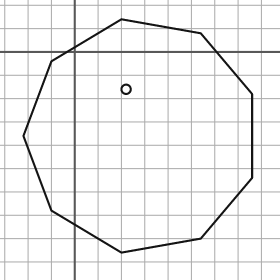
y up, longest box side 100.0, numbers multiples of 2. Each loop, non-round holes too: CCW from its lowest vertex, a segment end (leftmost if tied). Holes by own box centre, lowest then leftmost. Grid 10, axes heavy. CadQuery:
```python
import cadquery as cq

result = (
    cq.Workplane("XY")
    .moveTo(20.0, -86.0)
    .lineTo(54.0, -80.0)
    .lineTo(76.0, -54.0)
    .lineTo(76.0, -18.0)
    .lineTo(54.0, 8.0)
    .lineTo(20.0, 14.0)
    .lineTo(-10.0, -4.0)
    .lineTo(-22.0, -36.0)
    .lineTo(-10.0, -68.0)
    .close()
    .moveTo(22.0, -16.0)
    .circle(2.0)
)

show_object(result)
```